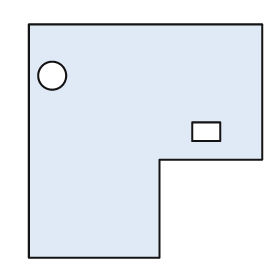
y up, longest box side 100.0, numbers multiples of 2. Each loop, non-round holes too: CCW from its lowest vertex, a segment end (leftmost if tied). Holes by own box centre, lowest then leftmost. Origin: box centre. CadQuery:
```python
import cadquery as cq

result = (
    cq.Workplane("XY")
    .moveTo(-50.0, -50.0)
    .lineTo(6.0, -50.0)
    .lineTo(6.0, -8.0)
    .lineTo(50.0, -8.0)
    .lineTo(50.0, 50.0)
    .lineTo(-50.0, 50.0)
    .close()
    .moveTo(20.0, 0.0)
    .lineTo(32.0, 0.0)
    .lineTo(32.0, 8.0)
    .lineTo(20.0, 8.0)
    .close()
    .moveTo(-40.0, 28.0)
    .circle(6.0)
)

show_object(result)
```